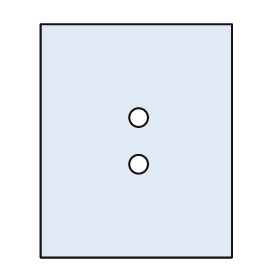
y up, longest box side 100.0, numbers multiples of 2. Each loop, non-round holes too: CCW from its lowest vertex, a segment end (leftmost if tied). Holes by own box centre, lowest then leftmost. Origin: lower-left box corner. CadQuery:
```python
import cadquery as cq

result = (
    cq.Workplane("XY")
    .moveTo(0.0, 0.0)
    .lineTo(82.0, 0.0)
    .lineTo(82.0, 100.0)
    .lineTo(0.0, 100.0)
    .close()
    .moveTo(42.0, 40.0)
    .circle(4.0)
    .moveTo(42.0, 60.0)
    .circle(4.0)
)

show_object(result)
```